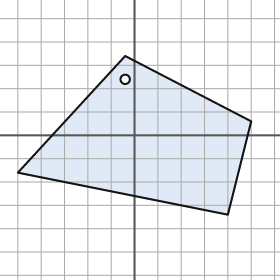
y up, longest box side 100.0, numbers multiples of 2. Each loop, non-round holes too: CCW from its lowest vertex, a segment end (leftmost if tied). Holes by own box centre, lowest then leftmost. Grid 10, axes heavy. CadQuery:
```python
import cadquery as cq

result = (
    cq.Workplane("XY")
    .moveTo(40.0, -34.0)
    .lineTo(50.0, 6.0)
    .lineTo(-4.0, 34.0)
    .lineTo(-50.0, -16.0)
    .close()
    .moveTo(-4.0, 24.0)
    .circle(2.0)
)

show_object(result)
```